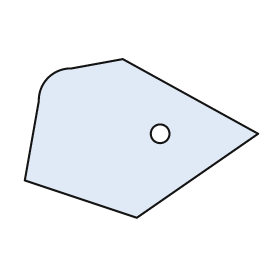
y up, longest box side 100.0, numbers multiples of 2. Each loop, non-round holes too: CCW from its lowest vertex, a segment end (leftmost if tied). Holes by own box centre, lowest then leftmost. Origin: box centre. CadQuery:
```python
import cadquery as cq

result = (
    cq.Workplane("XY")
    .moveTo(-2.0, -34.0)
    .lineTo(50.0, 2.0)
    .lineTo(-8.0, 34.0)
    .lineTo(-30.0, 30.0)
    .threePointArc((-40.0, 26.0), (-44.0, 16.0))
    .lineTo(-50.0, -18.0)
    .close()
    .moveTo(8.0, 2.0)
    .circle(4.0)
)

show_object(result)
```